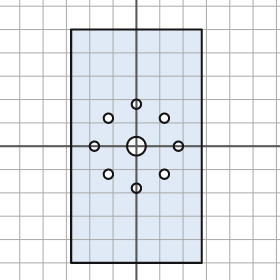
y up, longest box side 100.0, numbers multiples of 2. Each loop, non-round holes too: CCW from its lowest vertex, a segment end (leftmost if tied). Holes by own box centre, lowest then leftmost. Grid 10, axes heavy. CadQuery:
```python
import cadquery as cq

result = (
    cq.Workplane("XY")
    .moveTo(-28.0, -50.0)
    .lineTo(28.0, -50.0)
    .lineTo(28.0, 50.0)
    .lineTo(-28.0, 50.0)
    .close()
    .moveTo(0.0, -18.0)
    .circle(2.0)
    .moveTo(-12.0, -12.0)
    .circle(2.0)
    .moveTo(12.0, -12.0)
    .circle(2.0)
    .moveTo(-18.0, 0.0)
    .circle(2.0)
    .moveTo(0.0, 0.0)
    .circle(4.0)
    .moveTo(18.0, 0.0)
    .circle(2.0)
    .moveTo(-12.0, 12.0)
    .circle(2.0)
    .moveTo(12.0, 12.0)
    .circle(2.0)
    .moveTo(0.0, 18.0)
    .circle(2.0)
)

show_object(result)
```